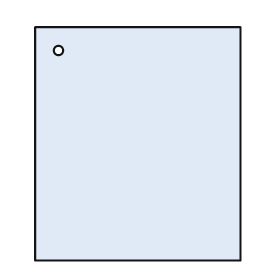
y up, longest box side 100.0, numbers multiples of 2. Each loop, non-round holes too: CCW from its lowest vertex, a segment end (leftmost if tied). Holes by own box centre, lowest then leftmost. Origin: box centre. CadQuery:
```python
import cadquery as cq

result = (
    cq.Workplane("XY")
    .moveTo(-44.0, -50.0)
    .lineTo(44.0, -50.0)
    .lineTo(44.0, 50.0)
    .lineTo(-44.0, 50.0)
    .close()
    .moveTo(-34.0, 40.0)
    .circle(2.0)
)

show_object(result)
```